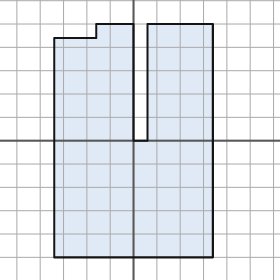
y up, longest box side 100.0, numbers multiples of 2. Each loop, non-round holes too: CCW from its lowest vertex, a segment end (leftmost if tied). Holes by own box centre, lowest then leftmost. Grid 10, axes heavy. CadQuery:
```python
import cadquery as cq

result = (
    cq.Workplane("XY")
    .moveTo(-34.0, -50.0)
    .lineTo(34.0, -50.0)
    .lineTo(34.0, 50.0)
    .lineTo(6.0, 50.0)
    .lineTo(6.0, 0.0)
    .lineTo(0.0, 0.0)
    .lineTo(0.0, 50.0)
    .lineTo(-16.0, 50.0)
    .lineTo(-16.0, 44.0)
    .lineTo(-34.0, 44.0)
    .close()
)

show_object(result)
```